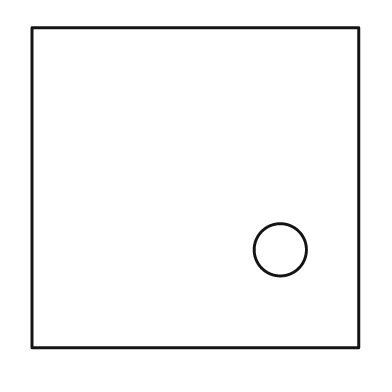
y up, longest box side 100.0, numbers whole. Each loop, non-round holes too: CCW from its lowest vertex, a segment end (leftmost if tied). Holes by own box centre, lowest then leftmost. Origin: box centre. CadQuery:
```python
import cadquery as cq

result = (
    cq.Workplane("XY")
    .moveTo(-50.0, -49.0)
    .lineTo(50.0, -49.0)
    .lineTo(50.0, 49.0)
    .lineTo(-50.0, 49.0)
    .close()
    .moveTo(26.0, -19.0)
    .circle(8.0)
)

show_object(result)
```